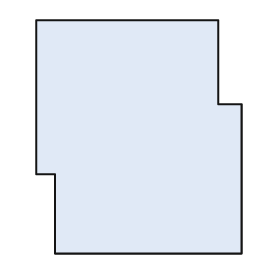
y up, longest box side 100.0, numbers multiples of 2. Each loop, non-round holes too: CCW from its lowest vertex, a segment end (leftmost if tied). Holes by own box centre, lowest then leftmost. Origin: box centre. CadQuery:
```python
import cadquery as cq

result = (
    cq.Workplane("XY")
    .moveTo(-36.0, -50.0)
    .lineTo(44.0, -50.0)
    .lineTo(44.0, 14.0)
    .lineTo(34.0, 14.0)
    .lineTo(34.0, 50.0)
    .lineTo(-44.0, 50.0)
    .lineTo(-44.0, -16.0)
    .lineTo(-36.0, -16.0)
    .close()
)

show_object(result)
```